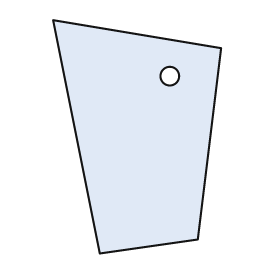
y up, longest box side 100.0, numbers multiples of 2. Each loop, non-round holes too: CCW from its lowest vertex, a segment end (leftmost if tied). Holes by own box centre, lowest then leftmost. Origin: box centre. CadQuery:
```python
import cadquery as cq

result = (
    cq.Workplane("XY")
    .moveTo(-16.0, -50.0)
    .lineTo(26.0, -44.0)
    .lineTo(36.0, 38.0)
    .lineTo(-36.0, 50.0)
    .close()
    .moveTo(14.0, 26.0)
    .circle(4.0)
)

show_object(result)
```